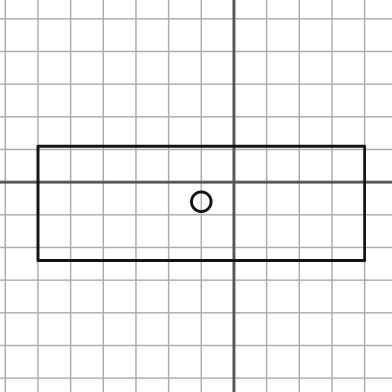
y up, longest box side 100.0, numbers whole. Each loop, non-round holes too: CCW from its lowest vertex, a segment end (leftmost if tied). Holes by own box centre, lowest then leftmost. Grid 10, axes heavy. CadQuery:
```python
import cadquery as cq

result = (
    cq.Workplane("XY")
    .moveTo(-60.0, -24.0)
    .lineTo(40.0, -24.0)
    .lineTo(40.0, 11.0)
    .lineTo(-60.0, 11.0)
    .close()
    .moveTo(-10.0, -6.0)
    .circle(3.0)
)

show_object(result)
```